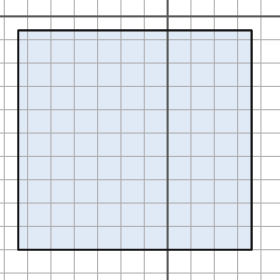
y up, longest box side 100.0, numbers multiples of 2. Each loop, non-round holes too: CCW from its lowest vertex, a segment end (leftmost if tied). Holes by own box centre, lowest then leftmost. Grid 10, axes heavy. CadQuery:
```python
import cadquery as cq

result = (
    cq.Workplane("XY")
    .moveTo(-64.0, -100.0)
    .lineTo(36.0, -100.0)
    .lineTo(36.0, -6.0)
    .lineTo(-64.0, -6.0)
    .close()
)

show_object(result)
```